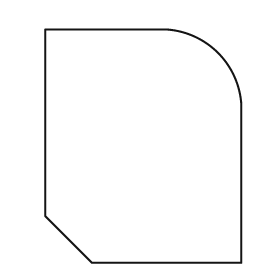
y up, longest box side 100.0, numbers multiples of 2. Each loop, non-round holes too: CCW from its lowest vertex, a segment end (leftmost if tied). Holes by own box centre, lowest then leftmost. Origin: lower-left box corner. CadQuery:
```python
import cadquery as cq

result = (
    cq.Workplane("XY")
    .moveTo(20.0, 0.0)
    .lineTo(84.0, 0.0)
    .lineTo(84.0, 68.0)
    .threePointArc((74.0, 90.0), (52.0, 100.0))
    .lineTo(0.0, 100.0)
    .lineTo(0.0, 20.0)
    .close()
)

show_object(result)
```